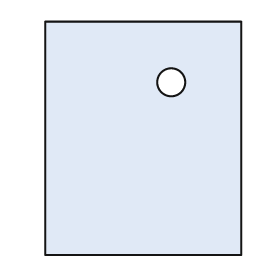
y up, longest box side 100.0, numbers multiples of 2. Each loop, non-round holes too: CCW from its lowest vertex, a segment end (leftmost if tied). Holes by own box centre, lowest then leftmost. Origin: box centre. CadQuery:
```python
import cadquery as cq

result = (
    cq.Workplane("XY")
    .moveTo(-42.0, -50.0)
    .lineTo(42.0, -50.0)
    .lineTo(42.0, 50.0)
    .lineTo(-42.0, 50.0)
    .close()
    .moveTo(12.0, 24.0)
    .circle(6.0)
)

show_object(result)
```